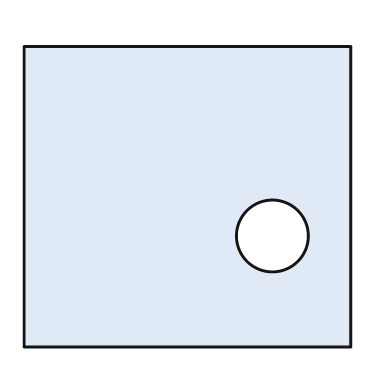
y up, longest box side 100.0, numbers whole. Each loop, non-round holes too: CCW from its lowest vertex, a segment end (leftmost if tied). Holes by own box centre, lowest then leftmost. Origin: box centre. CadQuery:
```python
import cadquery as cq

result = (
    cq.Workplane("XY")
    .moveTo(-50.0, -46.0)
    .lineTo(50.0, -46.0)
    .lineTo(50.0, 46.0)
    .lineTo(-50.0, 46.0)
    .close()
    .moveTo(26.0, -12.0)
    .circle(11.0)
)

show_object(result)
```